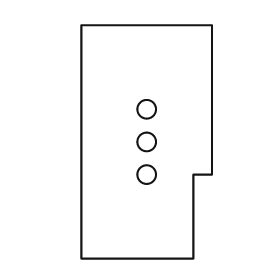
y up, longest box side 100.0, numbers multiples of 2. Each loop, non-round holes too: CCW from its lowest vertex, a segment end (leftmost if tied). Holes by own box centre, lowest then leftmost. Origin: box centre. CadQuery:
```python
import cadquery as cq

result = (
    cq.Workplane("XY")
    .moveTo(-28.0, -50.0)
    .lineTo(20.0, -50.0)
    .lineTo(20.0, -14.0)
    .lineTo(28.0, -14.0)
    .lineTo(28.0, 50.0)
    .lineTo(-28.0, 50.0)
    .close()
    .moveTo(0.0, -14.0)
    .circle(4.0)
    .moveTo(0.0, 0.0)
    .circle(4.0)
    .moveTo(0.0, 14.0)
    .circle(4.0)
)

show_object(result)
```